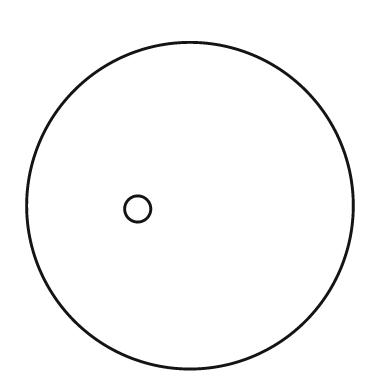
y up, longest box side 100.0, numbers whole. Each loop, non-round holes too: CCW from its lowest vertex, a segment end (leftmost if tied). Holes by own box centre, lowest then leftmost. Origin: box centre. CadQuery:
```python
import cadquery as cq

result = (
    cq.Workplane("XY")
    .moveTo(0.0, 0.0)
    .circle(50.0)
    .moveTo(-16.0, -1.0)
    .circle(4.0)
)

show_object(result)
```